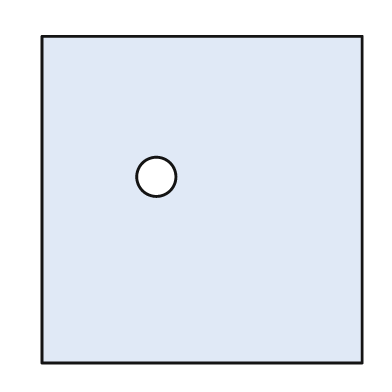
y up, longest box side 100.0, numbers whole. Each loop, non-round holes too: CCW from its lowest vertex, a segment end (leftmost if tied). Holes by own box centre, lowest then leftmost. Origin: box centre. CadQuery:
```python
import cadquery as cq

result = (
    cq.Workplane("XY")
    .moveTo(-49.0, -50.0)
    .lineTo(49.0, -50.0)
    .lineTo(49.0, 50.0)
    .lineTo(-49.0, 50.0)
    .close()
    .moveTo(-14.0, 7.0)
    .circle(6.0)
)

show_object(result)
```